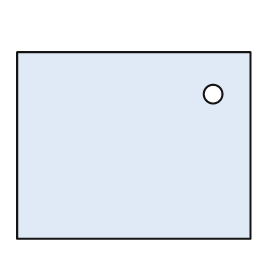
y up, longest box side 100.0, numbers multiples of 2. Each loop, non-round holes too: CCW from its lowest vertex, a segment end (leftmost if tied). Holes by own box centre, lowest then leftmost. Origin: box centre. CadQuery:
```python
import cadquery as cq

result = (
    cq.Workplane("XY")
    .moveTo(-50.0, -40.0)
    .lineTo(50.0, -40.0)
    .lineTo(50.0, 40.0)
    .lineTo(-50.0, 40.0)
    .close()
    .moveTo(34.0, 22.0)
    .circle(4.0)
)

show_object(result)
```